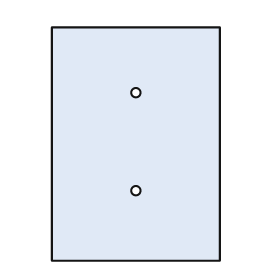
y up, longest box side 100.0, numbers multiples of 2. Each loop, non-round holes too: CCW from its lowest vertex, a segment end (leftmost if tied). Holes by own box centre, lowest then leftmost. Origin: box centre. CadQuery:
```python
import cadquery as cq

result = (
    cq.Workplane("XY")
    .moveTo(-36.0, -50.0)
    .lineTo(36.0, -50.0)
    .lineTo(36.0, 50.0)
    .lineTo(-36.0, 50.0)
    .close()
    .moveTo(0.0, -20.0)
    .circle(2.0)
    .moveTo(0.0, 22.0)
    .circle(2.0)
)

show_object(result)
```